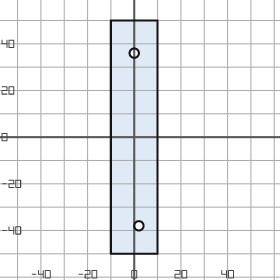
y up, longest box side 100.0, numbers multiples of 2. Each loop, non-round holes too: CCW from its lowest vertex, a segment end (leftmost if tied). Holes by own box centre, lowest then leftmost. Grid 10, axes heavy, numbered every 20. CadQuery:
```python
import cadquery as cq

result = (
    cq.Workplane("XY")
    .moveTo(-10.0, -50.0)
    .lineTo(10.0, -50.0)
    .lineTo(10.0, 50.0)
    .lineTo(-10.0, 50.0)
    .close()
    .moveTo(2.0, -38.0)
    .circle(2.0)
    .moveTo(0.0, 36.0)
    .circle(2.0)
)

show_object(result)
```